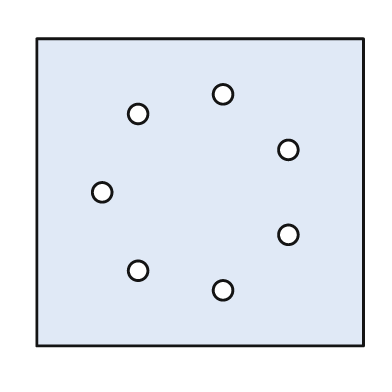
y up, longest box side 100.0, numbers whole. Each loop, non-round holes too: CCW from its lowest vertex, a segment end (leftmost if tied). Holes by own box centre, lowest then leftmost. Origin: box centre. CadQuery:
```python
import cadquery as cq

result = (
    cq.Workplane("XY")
    .moveTo(-50.0, -47.0)
    .lineTo(50.0, -47.0)
    .lineTo(50.0, 47.0)
    .lineTo(-50.0, 47.0)
    .close()
    .moveTo(7.0, -30.0)
    .circle(3.0)
    .moveTo(-19.0, -24.0)
    .circle(3.0)
    .moveTo(27.0, -13.0)
    .circle(3.0)
    .moveTo(-30.0, 0.0)
    .circle(3.0)
    .moveTo(27.0, 13.0)
    .circle(3.0)
    .moveTo(-19.0, 24.0)
    .circle(3.0)
    .moveTo(7.0, 30.0)
    .circle(3.0)
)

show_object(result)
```